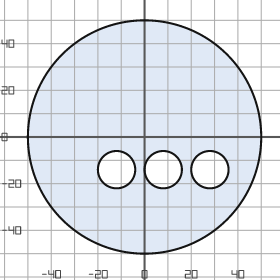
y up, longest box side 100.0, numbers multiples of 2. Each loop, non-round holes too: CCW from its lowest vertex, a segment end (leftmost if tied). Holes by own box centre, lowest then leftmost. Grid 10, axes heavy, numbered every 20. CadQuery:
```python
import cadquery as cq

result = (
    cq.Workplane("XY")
    .moveTo(0.0, 0.0)
    .circle(50.0)
    .moveTo(-12.0, -14.0)
    .circle(8.0)
    .moveTo(8.0, -14.0)
    .circle(8.0)
    .moveTo(28.0, -14.0)
    .circle(8.0)
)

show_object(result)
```